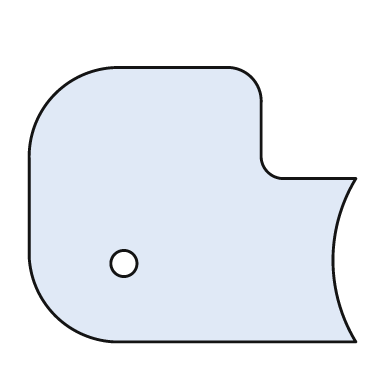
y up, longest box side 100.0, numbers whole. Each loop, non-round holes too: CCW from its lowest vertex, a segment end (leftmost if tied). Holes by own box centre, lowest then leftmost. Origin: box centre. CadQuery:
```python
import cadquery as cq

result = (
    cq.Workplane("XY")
    .moveTo(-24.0, -42.0)
    .lineTo(50.0, -42.0)
    .threePointArc((43.0, -17.0), (50.0, 8.0))
    .lineTo(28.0, 8.0)
    .threePointArc((23.0, 10.0), (21.0, 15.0))
    .lineTo(21.0, 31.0)
    .threePointArc((18.0, 39.0), (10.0, 42.0))
    .lineTo(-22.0, 42.0)
    .threePointArc((-42.0, 34.0), (-50.0, 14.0))
    .lineTo(-50.0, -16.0)
    .threePointArc((-42.0, -34.0), (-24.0, -42.0))
    .close()
    .moveTo(-21.0, -18.0)
    .circle(4.0)
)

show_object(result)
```